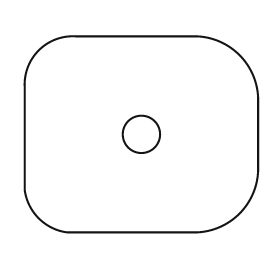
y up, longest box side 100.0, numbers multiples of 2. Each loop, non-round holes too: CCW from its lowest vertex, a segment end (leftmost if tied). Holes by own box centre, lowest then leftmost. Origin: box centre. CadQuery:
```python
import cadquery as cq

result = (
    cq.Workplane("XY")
    .moveTo(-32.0, -42.0)
    .lineTo(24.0, -42.0)
    .threePointArc((42.0, -34.0), (50.0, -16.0))
    .lineTo(50.0, 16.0)
    .threePointArc((42.0, 34.0), (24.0, 42.0))
    .lineTo(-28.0, 42.0)
    .threePointArc((-44.0, 36.0), (-50.0, 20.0))
    .lineTo(-50.0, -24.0)
    .threePointArc((-44.0, -36.0), (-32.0, -42.0))
    .close()
    .moveTo(0.0, 0.0)
    .circle(8.0)
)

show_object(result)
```